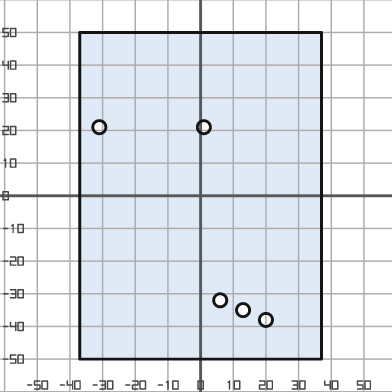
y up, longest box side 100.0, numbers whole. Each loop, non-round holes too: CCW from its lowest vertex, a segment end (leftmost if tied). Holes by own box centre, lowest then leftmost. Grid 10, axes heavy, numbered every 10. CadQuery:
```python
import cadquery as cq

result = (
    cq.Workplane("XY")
    .moveTo(-37.0, -50.0)
    .lineTo(37.0, -50.0)
    .lineTo(37.0, 50.0)
    .lineTo(-37.0, 50.0)
    .close()
    .moveTo(20.0, -38.0)
    .circle(2.0)
    .moveTo(13.0, -35.0)
    .circle(2.0)
    .moveTo(6.0, -32.0)
    .circle(2.0)
    .moveTo(-31.0, 21.0)
    .circle(2.0)
    .moveTo(1.0, 21.0)
    .circle(2.0)
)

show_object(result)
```